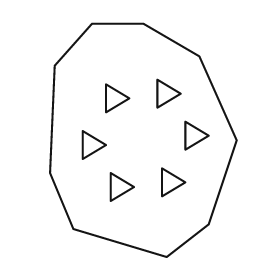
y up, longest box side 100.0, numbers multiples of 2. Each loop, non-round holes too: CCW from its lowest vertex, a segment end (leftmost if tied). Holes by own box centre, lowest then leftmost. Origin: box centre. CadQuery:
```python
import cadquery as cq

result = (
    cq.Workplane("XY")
    .moveTo(10.0, -50.0)
    .lineTo(28.0, -36.0)
    .lineTo(40.0, 0.0)
    .lineTo(24.0, 36.0)
    .lineTo(0.0, 50.0)
    .lineTo(-22.0, 50.0)
    .lineTo(-38.0, 32.0)
    .lineTo(-40.0, -14.0)
    .lineTo(-30.0, -38.0)
    .close()
    .moveTo(-14.0, -26.0)
    .lineTo(-4.0, -20.0)
    .lineTo(-14.0, -14.0)
    .close()
    .moveTo(8.0, -24.0)
    .lineTo(18.0, -18.0)
    .lineTo(8.0, -12.0)
    .close()
    .moveTo(-26.0, -8.0)
    .lineTo(-16.0, -2.0)
    .lineTo(-26.0, 4.0)
    .close()
    .moveTo(18.0, -4.0)
    .lineTo(28.0, 2.0)
    .lineTo(18.0, 8.0)
    .close()
    .moveTo(-16.0, 12.0)
    .lineTo(-6.0, 18.0)
    .lineTo(-16.0, 24.0)
    .close()
    .moveTo(6.0, 14.0)
    .lineTo(16.0, 20.0)
    .lineTo(6.0, 26.0)
    .close()
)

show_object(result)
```